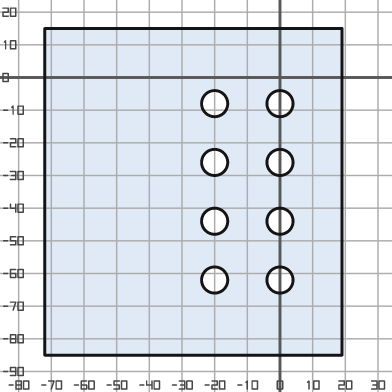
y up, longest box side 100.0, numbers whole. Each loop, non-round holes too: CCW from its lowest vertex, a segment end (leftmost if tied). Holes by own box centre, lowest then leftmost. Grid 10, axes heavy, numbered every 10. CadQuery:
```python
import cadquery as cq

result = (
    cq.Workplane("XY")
    .moveTo(-72.0, -85.0)
    .lineTo(19.0, -85.0)
    .lineTo(19.0, 15.0)
    .lineTo(-72.0, 15.0)
    .close()
    .moveTo(-20.0, -62.0)
    .circle(4.0)
    .moveTo(0.0, -62.0)
    .circle(4.0)
    .moveTo(-20.0, -44.0)
    .circle(4.0)
    .moveTo(0.0, -44.0)
    .circle(4.0)
    .moveTo(-20.0, -26.0)
    .circle(4.0)
    .moveTo(0.0, -26.0)
    .circle(4.0)
    .moveTo(-20.0, -8.0)
    .circle(4.0)
    .moveTo(0.0, -8.0)
    .circle(4.0)
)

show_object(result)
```